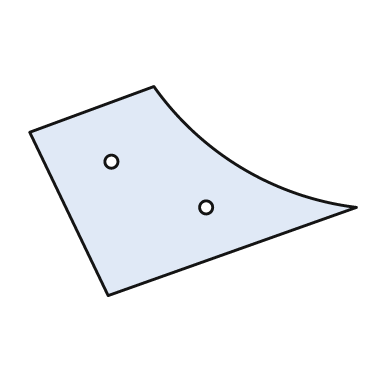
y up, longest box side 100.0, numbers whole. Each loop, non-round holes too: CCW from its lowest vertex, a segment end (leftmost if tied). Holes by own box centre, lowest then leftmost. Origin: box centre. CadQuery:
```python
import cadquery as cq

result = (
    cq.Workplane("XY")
    .moveTo(-26.0, -32.0)
    .lineTo(50.0, -5.0)
    .threePointArc((15.0, 7.0), (-12.0, 32.0))
    .lineTo(-50.0, 18.0)
    .close()
    .moveTo(4.0, -5.0)
    .circle(2.0)
    .moveTo(-25.0, 9.0)
    .circle(2.0)
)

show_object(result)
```